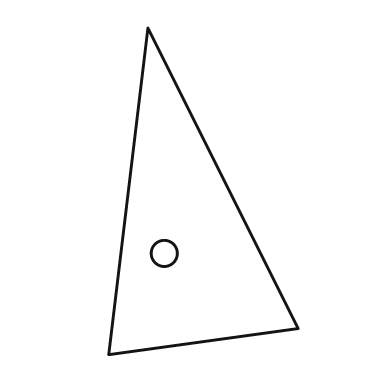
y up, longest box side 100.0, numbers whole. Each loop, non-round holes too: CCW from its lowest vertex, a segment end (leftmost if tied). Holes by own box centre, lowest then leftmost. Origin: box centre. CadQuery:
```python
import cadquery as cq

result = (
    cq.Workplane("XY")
    .moveTo(-29.0, -50.0)
    .lineTo(29.0, -42.0)
    .lineTo(-17.0, 50.0)
    .close()
    .moveTo(-12.0, -19.0)
    .circle(4.0)
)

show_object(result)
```